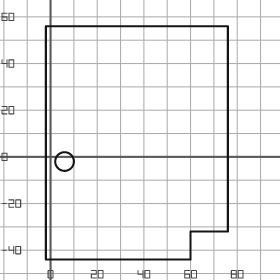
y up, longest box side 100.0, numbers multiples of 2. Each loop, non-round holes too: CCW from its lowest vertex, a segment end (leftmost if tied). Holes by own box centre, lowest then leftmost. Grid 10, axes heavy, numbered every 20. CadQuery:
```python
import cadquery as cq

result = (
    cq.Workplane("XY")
    .moveTo(-2.0, -44.0)
    .lineTo(60.0, -44.0)
    .lineTo(60.0, -32.0)
    .lineTo(76.0, -32.0)
    .lineTo(76.0, 56.0)
    .lineTo(-2.0, 56.0)
    .close()
    .moveTo(6.0, -2.0)
    .circle(4.0)
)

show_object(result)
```